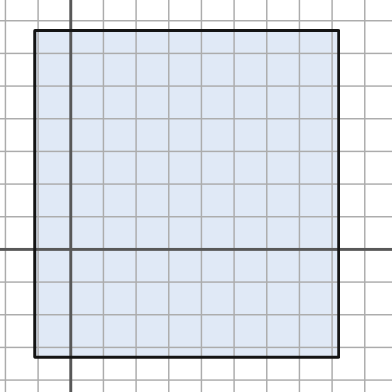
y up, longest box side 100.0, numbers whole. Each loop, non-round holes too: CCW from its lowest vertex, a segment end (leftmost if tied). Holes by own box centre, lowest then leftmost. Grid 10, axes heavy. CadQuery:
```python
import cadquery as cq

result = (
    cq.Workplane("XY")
    .moveTo(-11.0, -33.0)
    .lineTo(82.0, -33.0)
    .lineTo(82.0, 67.0)
    .lineTo(-11.0, 67.0)
    .close()
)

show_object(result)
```